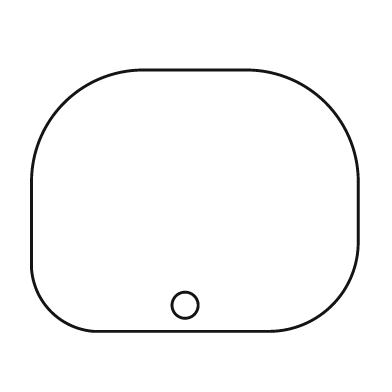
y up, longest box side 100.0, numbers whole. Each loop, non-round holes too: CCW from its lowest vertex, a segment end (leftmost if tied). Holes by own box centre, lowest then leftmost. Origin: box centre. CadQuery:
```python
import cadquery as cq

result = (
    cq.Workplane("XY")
    .moveTo(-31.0, -40.0)
    .lineTo(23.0, -40.0)
    .threePointArc((42.0, -32.0), (50.0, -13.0))
    .lineTo(50.0, 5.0)
    .threePointArc((40.0, 30.0), (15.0, 40.0))
    .lineTo(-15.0, 40.0)
    .threePointArc((-40.0, 30.0), (-50.0, 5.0))
    .lineTo(-50.0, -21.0)
    .threePointArc((-44.0, -34.0), (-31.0, -40.0))
    .close()
    .moveTo(-3.0, -32.0)
    .circle(4.0)
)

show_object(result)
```